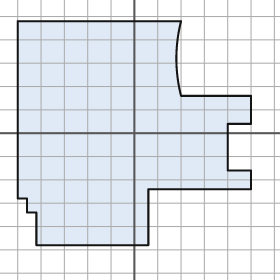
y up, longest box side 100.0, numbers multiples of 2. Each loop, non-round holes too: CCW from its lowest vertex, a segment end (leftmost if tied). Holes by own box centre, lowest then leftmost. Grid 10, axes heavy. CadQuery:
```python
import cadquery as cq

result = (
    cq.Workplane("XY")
    .moveTo(-42.0, -48.0)
    .lineTo(6.0, -48.0)
    .lineTo(6.0, -24.0)
    .lineTo(50.0, -24.0)
    .lineTo(50.0, -16.0)
    .lineTo(40.0, -16.0)
    .lineTo(40.0, 4.0)
    .lineTo(50.0, 4.0)
    .lineTo(50.0, 16.0)
    .lineTo(20.0, 16.0)
    .threePointArc((18.0, 32.0), (20.0, 48.0))
    .lineTo(-50.0, 48.0)
    .lineTo(-50.0, -28.0)
    .lineTo(-46.0, -28.0)
    .lineTo(-46.0, -34.0)
    .lineTo(-42.0, -34.0)
    .close()
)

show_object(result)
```